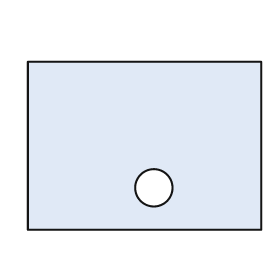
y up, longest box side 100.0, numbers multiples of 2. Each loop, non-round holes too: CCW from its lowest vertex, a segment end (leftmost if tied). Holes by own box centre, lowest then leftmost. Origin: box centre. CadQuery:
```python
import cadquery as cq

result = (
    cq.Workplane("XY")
    .moveTo(-50.0, -36.0)
    .lineTo(50.0, -36.0)
    .lineTo(50.0, 36.0)
    .lineTo(-50.0, 36.0)
    .close()
    .moveTo(4.0, -18.0)
    .circle(8.0)
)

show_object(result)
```